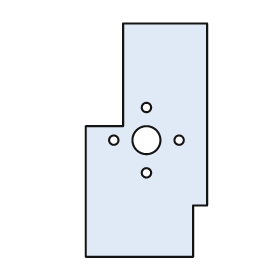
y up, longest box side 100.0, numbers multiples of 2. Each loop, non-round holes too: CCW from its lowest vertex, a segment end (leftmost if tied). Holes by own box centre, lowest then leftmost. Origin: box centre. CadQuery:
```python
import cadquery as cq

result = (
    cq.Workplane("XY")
    .moveTo(-26.0, -50.0)
    .lineTo(20.0, -50.0)
    .lineTo(20.0, -28.0)
    .lineTo(26.0, -28.0)
    .lineTo(26.0, 50.0)
    .lineTo(-10.0, 50.0)
    .lineTo(-10.0, 6.0)
    .lineTo(-26.0, 6.0)
    .close()
    .moveTo(0.0, -14.0)
    .circle(2.0)
    .moveTo(-14.0, 0.0)
    .circle(2.0)
    .moveTo(0.0, 0.0)
    .circle(6.0)
    .moveTo(14.0, 0.0)
    .circle(2.0)
    .moveTo(0.0, 14.0)
    .circle(2.0)
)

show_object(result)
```